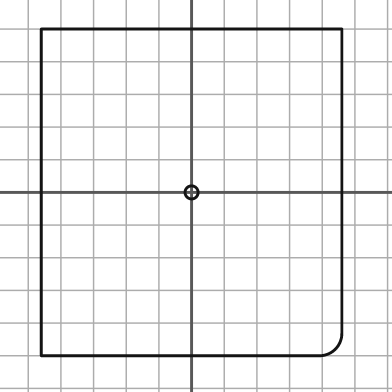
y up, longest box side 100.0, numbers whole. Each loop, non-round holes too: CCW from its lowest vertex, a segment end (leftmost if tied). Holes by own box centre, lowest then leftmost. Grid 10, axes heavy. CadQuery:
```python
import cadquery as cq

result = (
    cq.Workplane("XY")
    .moveTo(-46.0, -50.0)
    .lineTo(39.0, -50.0)
    .threePointArc((44.0, -48.0), (46.0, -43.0))
    .lineTo(46.0, 50.0)
    .lineTo(-46.0, 50.0)
    .close()
    .moveTo(0.0, 0.0)
    .circle(2.0)
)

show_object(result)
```